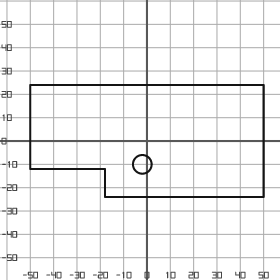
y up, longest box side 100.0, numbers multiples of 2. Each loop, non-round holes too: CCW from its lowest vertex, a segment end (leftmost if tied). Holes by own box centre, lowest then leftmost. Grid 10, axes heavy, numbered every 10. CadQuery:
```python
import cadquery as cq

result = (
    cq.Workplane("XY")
    .moveTo(-18.0, -24.0)
    .lineTo(50.0, -24.0)
    .lineTo(50.0, 24.0)
    .lineTo(-50.0, 24.0)
    .lineTo(-50.0, -12.0)
    .lineTo(-18.0, -12.0)
    .close()
    .moveTo(-2.0, -10.0)
    .circle(4.0)
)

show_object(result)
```